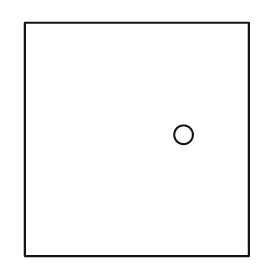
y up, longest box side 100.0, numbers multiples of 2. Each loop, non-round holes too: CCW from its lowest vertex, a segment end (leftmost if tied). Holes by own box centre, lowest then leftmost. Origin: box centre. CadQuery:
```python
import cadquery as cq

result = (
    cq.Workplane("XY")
    .moveTo(-48.0, -50.0)
    .lineTo(48.0, -50.0)
    .lineTo(48.0, 50.0)
    .lineTo(-48.0, 50.0)
    .close()
    .moveTo(20.0, 2.0)
    .circle(4.0)
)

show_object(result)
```